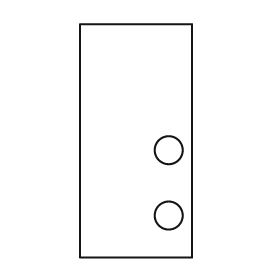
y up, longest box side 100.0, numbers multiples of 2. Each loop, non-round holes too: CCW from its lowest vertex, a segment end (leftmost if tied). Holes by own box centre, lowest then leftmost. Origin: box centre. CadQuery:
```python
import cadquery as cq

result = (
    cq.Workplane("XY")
    .moveTo(-24.0, -50.0)
    .lineTo(24.0, -50.0)
    .lineTo(24.0, 50.0)
    .lineTo(-24.0, 50.0)
    .close()
    .moveTo(14.0, -32.0)
    .circle(6.0)
    .moveTo(14.0, -4.0)
    .circle(6.0)
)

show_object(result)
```